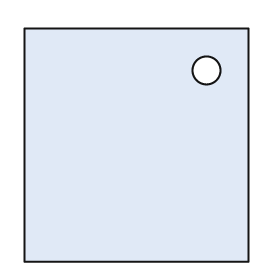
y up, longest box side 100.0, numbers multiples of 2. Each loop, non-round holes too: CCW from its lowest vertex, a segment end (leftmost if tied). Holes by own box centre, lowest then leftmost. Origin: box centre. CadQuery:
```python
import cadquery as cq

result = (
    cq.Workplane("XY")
    .moveTo(-48.0, -50.0)
    .lineTo(48.0, -50.0)
    .lineTo(48.0, 50.0)
    .lineTo(-48.0, 50.0)
    .close()
    .moveTo(30.0, 32.0)
    .circle(6.0)
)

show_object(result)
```